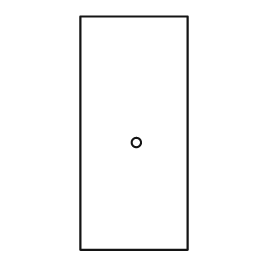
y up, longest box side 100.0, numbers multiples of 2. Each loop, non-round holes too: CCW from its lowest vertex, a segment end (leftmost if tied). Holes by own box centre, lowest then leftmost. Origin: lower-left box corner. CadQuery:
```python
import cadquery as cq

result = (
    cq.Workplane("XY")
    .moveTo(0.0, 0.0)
    .lineTo(46.0, 0.0)
    .lineTo(46.0, 100.0)
    .lineTo(0.0, 100.0)
    .close()
    .moveTo(24.0, 46.0)
    .circle(2.0)
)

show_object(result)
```